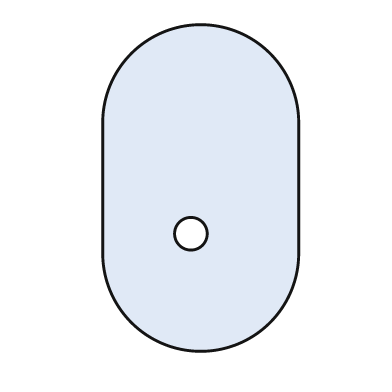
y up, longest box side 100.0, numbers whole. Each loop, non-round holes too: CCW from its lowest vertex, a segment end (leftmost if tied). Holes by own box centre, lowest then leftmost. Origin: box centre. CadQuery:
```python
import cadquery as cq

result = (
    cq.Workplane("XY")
    .moveTo(-30.0, -20.0)
    .threePointArc((0.0, -50.0), (30.0, -20.0))
    .lineTo(30.0, 20.0)
    .threePointArc((0.0, 50.0), (-30.0, 20.0))
    .close()
    .moveTo(-3.0, -14.0)
    .circle(5.0)
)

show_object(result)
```